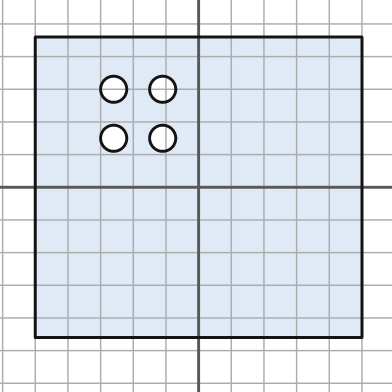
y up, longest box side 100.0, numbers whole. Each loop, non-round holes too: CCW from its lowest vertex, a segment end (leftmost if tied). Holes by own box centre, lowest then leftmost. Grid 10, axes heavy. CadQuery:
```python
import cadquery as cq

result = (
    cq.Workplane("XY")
    .moveTo(-50.0, -46.0)
    .lineTo(50.0, -46.0)
    .lineTo(50.0, 46.0)
    .lineTo(-50.0, 46.0)
    .close()
    .moveTo(-26.0, 15.0)
    .circle(4.0)
    .moveTo(-11.0, 15.0)
    .circle(4.0)
    .moveTo(-26.0, 30.0)
    .circle(4.0)
    .moveTo(-11.0, 30.0)
    .circle(4.0)
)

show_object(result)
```